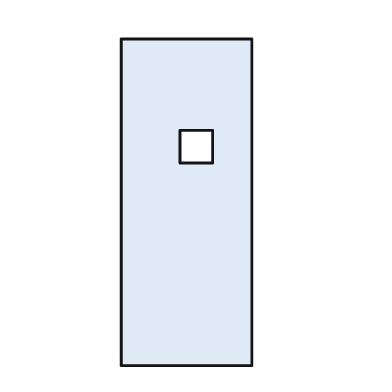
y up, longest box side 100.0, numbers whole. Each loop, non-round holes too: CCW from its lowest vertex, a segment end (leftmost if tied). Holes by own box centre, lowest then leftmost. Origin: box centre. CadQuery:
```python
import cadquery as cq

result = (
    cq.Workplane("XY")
    .moveTo(-20.0, -50.0)
    .lineTo(20.0, -50.0)
    .lineTo(20.0, 50.0)
    .lineTo(-20.0, 50.0)
    .close()
    .moveTo(-2.0, 12.0)
    .lineTo(8.0, 12.0)
    .lineTo(8.0, 22.0)
    .lineTo(-2.0, 22.0)
    .close()
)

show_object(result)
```